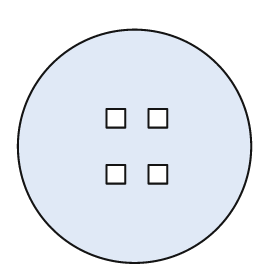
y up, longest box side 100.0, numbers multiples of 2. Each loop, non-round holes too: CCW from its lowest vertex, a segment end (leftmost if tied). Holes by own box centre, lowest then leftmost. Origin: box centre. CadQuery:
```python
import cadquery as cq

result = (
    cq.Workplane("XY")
    .moveTo(0.0, 0.0)
    .circle(50.0)
    .moveTo(-12.0, -16.0)
    .lineTo(-4.0, -16.0)
    .lineTo(-4.0, -8.0)
    .lineTo(-12.0, -8.0)
    .close()
    .moveTo(6.0, -16.0)
    .lineTo(14.0, -16.0)
    .lineTo(14.0, -8.0)
    .lineTo(6.0, -8.0)
    .close()
    .moveTo(-12.0, 8.0)
    .lineTo(-4.0, 8.0)
    .lineTo(-4.0, 16.0)
    .lineTo(-12.0, 16.0)
    .close()
    .moveTo(6.0, 8.0)
    .lineTo(14.0, 8.0)
    .lineTo(14.0, 16.0)
    .lineTo(6.0, 16.0)
    .close()
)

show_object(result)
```